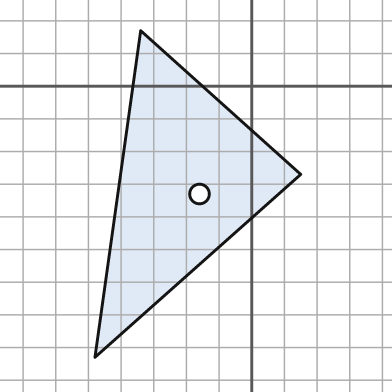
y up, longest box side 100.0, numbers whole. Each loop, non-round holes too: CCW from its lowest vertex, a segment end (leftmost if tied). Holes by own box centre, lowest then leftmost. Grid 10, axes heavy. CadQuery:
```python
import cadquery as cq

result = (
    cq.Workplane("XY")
    .moveTo(-48.0, -83.0)
    .lineTo(15.0, -27.0)
    .lineTo(-34.0, 17.0)
    .close()
    .moveTo(-16.0, -33.0)
    .circle(3.0)
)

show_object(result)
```